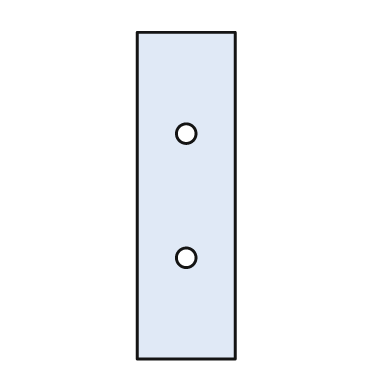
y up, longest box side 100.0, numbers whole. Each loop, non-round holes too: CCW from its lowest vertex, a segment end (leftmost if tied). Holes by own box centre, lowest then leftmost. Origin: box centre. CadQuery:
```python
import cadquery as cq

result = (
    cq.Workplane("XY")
    .moveTo(-15.0, -50.0)
    .lineTo(15.0, -50.0)
    .lineTo(15.0, 50.0)
    .lineTo(-15.0, 50.0)
    .close()
    .moveTo(0.0, -19.0)
    .circle(3.0)
    .moveTo(0.0, 19.0)
    .circle(3.0)
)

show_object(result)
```